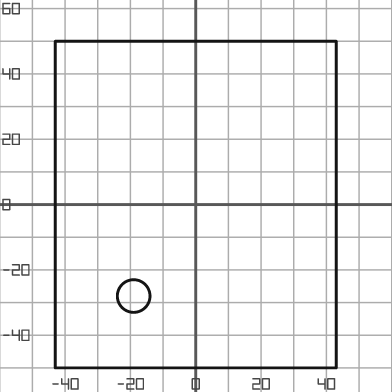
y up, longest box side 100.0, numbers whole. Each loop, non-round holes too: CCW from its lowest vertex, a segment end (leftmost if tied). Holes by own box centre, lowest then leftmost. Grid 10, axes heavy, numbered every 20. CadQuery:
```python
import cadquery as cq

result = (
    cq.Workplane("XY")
    .moveTo(-43.0, -50.0)
    .lineTo(43.0, -50.0)
    .lineTo(43.0, 50.0)
    .lineTo(-43.0, 50.0)
    .close()
    .moveTo(-19.0, -28.0)
    .circle(5.0)
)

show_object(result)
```